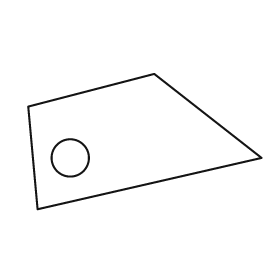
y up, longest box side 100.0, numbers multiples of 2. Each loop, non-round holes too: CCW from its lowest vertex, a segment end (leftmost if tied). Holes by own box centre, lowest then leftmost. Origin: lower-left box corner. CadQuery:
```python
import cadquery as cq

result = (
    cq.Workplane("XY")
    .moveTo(4.0, 0.0)
    .lineTo(100.0, 22.0)
    .lineTo(54.0, 58.0)
    .lineTo(0.0, 44.0)
    .close()
    .moveTo(18.0, 22.0)
    .circle(8.0)
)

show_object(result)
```